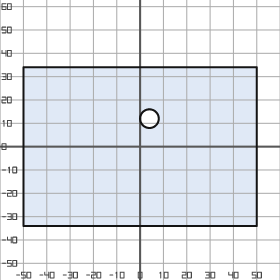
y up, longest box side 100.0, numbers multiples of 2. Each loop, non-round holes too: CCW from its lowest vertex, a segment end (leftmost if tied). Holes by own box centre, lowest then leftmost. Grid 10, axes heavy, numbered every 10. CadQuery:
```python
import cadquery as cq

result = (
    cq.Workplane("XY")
    .moveTo(-50.0, -34.0)
    .lineTo(50.0, -34.0)
    .lineTo(50.0, 34.0)
    .lineTo(-50.0, 34.0)
    .close()
    .moveTo(4.0, 12.0)
    .circle(4.0)
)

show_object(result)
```